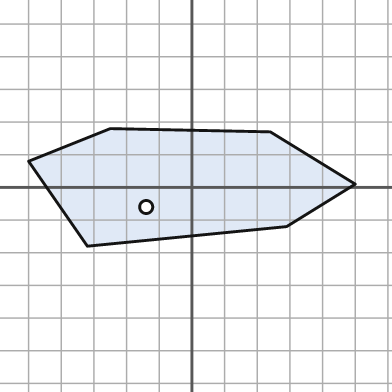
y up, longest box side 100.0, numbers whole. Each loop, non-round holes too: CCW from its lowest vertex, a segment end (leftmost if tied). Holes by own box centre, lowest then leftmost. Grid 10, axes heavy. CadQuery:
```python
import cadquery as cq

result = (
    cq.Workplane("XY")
    .moveTo(-32.0, -18.0)
    .lineTo(29.0, -12.0)
    .lineTo(50.0, 1.0)
    .lineTo(24.0, 17.0)
    .lineTo(-25.0, 18.0)
    .lineTo(-50.0, 8.0)
    .close()
    .moveTo(-14.0, -6.0)
    .circle(2.0)
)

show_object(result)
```